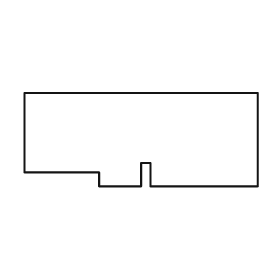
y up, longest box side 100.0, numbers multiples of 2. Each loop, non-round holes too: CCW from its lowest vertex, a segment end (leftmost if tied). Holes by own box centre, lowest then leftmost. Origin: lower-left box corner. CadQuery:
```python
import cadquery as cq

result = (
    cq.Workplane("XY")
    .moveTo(32.0, 0.0)
    .lineTo(50.0, 0.0)
    .lineTo(50.0, 10.0)
    .lineTo(54.0, 10.0)
    .lineTo(54.0, 0.0)
    .lineTo(100.0, 0.0)
    .lineTo(100.0, 40.0)
    .lineTo(0.0, 40.0)
    .lineTo(0.0, 6.0)
    .lineTo(32.0, 6.0)
    .close()
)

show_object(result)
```